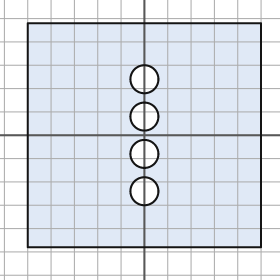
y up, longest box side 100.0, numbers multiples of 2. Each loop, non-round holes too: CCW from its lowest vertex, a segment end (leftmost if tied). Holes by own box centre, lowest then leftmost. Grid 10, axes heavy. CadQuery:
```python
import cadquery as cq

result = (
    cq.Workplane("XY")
    .moveTo(-50.0, -48.0)
    .lineTo(50.0, -48.0)
    .lineTo(50.0, 48.0)
    .lineTo(-50.0, 48.0)
    .close()
    .moveTo(0.0, -24.0)
    .circle(6.0)
    .moveTo(0.0, -8.0)
    .circle(6.0)
    .moveTo(0.0, 8.0)
    .circle(6.0)
    .moveTo(0.0, 24.0)
    .circle(6.0)
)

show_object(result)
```